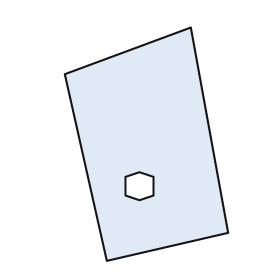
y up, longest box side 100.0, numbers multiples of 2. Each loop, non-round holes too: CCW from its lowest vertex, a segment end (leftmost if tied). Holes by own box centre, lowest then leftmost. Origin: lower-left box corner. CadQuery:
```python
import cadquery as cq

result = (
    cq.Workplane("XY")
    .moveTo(18.0, 0.0)
    .lineTo(70.0, 12.0)
    .lineTo(54.0, 100.0)
    .lineTo(0.0, 80.0)
    .close()
    .moveTo(32.0, 26.0)
    .lineTo(38.0, 28.0)
    .lineTo(38.0, 36.0)
    .lineTo(32.0, 38.0)
    .lineTo(26.0, 36.0)
    .lineTo(26.0, 28.0)
    .close()
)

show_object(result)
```